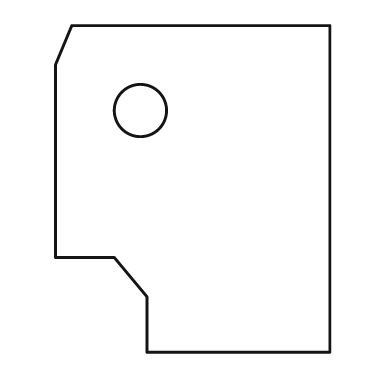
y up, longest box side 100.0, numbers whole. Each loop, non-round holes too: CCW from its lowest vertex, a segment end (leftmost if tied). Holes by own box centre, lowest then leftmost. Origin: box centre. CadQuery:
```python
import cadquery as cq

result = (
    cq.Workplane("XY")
    .moveTo(-14.0, -50.0)
    .lineTo(42.0, -50.0)
    .lineTo(42.0, 50.0)
    .lineTo(-37.0, 50.0)
    .lineTo(-42.0, 38.0)
    .lineTo(-42.0, -21.0)
    .lineTo(-24.0, -21.0)
    .lineTo(-14.0, -33.0)
    .close()
    .moveTo(-16.0, 24.0)
    .circle(8.0)
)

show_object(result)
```